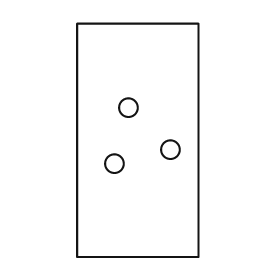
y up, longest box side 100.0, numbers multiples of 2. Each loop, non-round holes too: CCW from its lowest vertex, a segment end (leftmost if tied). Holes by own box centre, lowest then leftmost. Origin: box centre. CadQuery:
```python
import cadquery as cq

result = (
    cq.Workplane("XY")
    .moveTo(-26.0, -50.0)
    .lineTo(26.0, -50.0)
    .lineTo(26.0, 50.0)
    .lineTo(-26.0, 50.0)
    .close()
    .moveTo(-10.0, -10.0)
    .circle(4.0)
    .moveTo(14.0, -4.0)
    .circle(4.0)
    .moveTo(-4.0, 14.0)
    .circle(4.0)
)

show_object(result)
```